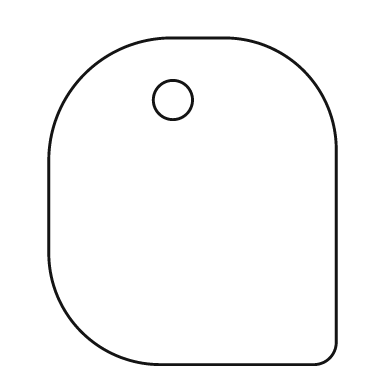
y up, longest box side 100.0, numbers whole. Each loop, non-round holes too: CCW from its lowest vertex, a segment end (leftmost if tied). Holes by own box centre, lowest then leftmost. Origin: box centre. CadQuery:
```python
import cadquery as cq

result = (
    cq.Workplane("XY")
    .moveTo(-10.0, -50.0)
    .lineTo(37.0, -50.0)
    .threePointArc((42.0, -48.0), (44.0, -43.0))
    .lineTo(44.0, 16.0)
    .threePointArc((34.0, 40.0), (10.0, 50.0))
    .lineTo(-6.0, 50.0)
    .threePointArc((-33.0, 39.0), (-44.0, 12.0))
    .lineTo(-44.0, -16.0)
    .threePointArc((-34.0, -40.0), (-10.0, -50.0))
    .close()
    .moveTo(-6.0, 31.0)
    .circle(6.0)
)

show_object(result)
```